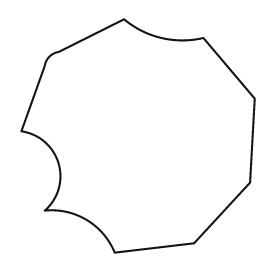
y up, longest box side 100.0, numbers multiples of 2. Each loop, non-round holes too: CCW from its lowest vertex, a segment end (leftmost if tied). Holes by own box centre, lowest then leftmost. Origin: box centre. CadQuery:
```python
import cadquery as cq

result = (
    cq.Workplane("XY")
    .moveTo(-10.0, -50.0)
    .lineTo(24.0, -46.0)
    .lineTo(48.0, -20.0)
    .lineTo(50.0, 16.0)
    .lineTo(28.0, 42.0)
    .threePointArc((10.0, 42.0), (-6.0, 50.0))
    .lineTo(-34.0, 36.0)
    .threePointArc((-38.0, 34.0), (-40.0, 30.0))
    .lineTo(-50.0, 2.0)
    .threePointArc((-34.0, -12.0), (-40.0, -32.0))
    .threePointArc((-22.0, -36.0), (-10.0, -50.0))
    .close()
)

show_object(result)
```